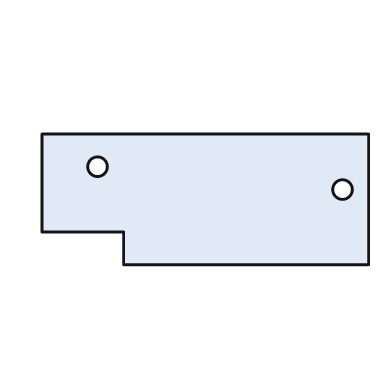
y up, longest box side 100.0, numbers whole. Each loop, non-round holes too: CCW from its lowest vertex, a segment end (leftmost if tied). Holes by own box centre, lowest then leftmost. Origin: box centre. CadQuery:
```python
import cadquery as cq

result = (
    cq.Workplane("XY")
    .moveTo(-25.0, -20.0)
    .lineTo(50.0, -20.0)
    .lineTo(50.0, 20.0)
    .lineTo(-50.0, 20.0)
    .lineTo(-50.0, -10.0)
    .lineTo(-25.0, -10.0)
    .close()
    .moveTo(42.0, 3.0)
    .circle(3.0)
    .moveTo(-33.0, 10.0)
    .circle(3.0)
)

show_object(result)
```